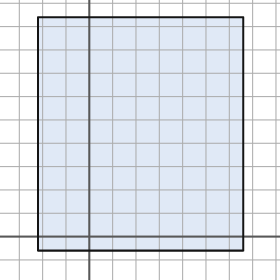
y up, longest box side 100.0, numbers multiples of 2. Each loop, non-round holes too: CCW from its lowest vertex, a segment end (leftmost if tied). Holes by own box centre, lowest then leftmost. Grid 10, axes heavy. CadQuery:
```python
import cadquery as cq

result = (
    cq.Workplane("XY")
    .moveTo(-22.0, -6.0)
    .lineTo(66.0, -6.0)
    .lineTo(66.0, 94.0)
    .lineTo(-22.0, 94.0)
    .close()
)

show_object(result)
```